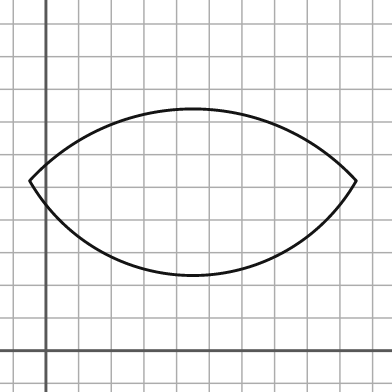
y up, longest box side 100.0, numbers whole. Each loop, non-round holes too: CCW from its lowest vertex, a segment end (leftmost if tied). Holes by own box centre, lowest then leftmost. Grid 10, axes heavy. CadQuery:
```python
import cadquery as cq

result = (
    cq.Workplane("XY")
    .moveTo(-5.0, 52.0)
    .threePointArc((45.0, 23.0), (95.0, 52.0))
    .threePointArc((45.0, 74.0), (-5.0, 52.0))
    .close()
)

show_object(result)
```